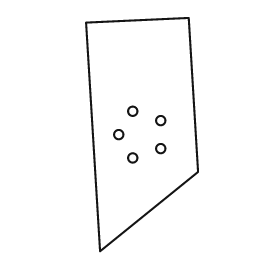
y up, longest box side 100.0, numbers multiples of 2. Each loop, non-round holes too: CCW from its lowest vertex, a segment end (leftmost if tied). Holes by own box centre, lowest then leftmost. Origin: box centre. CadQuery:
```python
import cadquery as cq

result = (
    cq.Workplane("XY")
    .moveTo(-18.0, -50.0)
    .lineTo(24.0, -16.0)
    .lineTo(20.0, 50.0)
    .lineTo(-24.0, 48.0)
    .close()
    .moveTo(-4.0, -10.0)
    .circle(2.0)
    .moveTo(8.0, -6.0)
    .circle(2.0)
    .moveTo(-10.0, 0.0)
    .circle(2.0)
    .moveTo(8.0, 6.0)
    .circle(2.0)
    .moveTo(-4.0, 10.0)
    .circle(2.0)
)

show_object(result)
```